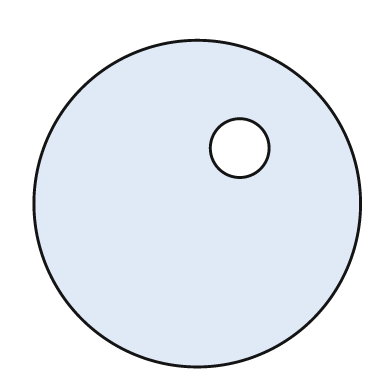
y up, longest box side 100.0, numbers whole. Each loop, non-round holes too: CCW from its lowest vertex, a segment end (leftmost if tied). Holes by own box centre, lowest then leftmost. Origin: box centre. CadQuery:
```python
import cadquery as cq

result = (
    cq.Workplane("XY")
    .moveTo(0.0, 0.0)
    .circle(50.0)
    .moveTo(13.0, 17.0)
    .circle(9.0)
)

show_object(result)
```